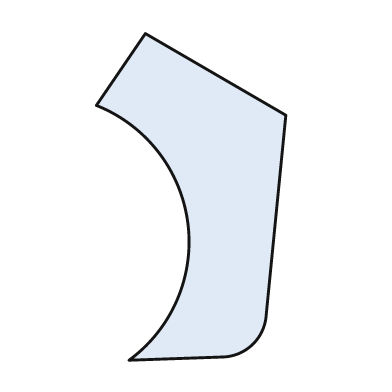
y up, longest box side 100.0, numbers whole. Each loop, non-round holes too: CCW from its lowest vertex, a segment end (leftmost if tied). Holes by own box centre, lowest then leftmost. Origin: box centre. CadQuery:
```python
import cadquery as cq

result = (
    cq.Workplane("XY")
    .moveTo(-19.0, -50.0)
    .lineTo(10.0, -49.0)
    .threePointArc((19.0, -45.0), (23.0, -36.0))
    .lineTo(29.0, 25.0)
    .lineTo(-14.0, 50.0)
    .lineTo(-29.0, 28.0)
    .threePointArc((-1.0, -8.0), (-19.0, -50.0))
    .close()
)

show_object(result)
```